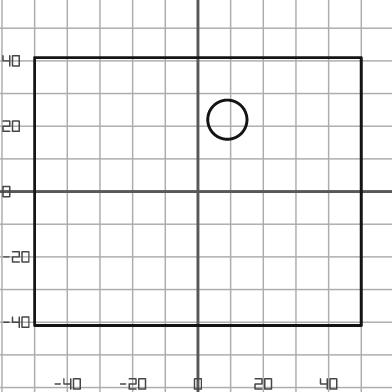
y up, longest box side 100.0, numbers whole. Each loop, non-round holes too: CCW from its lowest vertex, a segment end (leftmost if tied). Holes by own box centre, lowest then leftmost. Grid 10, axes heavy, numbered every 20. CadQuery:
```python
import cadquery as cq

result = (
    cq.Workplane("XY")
    .moveTo(-50.0, -41.0)
    .lineTo(50.0, -41.0)
    .lineTo(50.0, 41.0)
    .lineTo(-50.0, 41.0)
    .close()
    .moveTo(9.0, 22.0)
    .circle(6.0)
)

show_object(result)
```